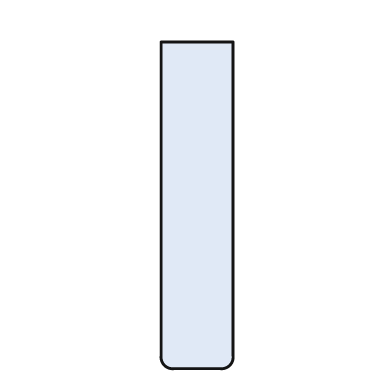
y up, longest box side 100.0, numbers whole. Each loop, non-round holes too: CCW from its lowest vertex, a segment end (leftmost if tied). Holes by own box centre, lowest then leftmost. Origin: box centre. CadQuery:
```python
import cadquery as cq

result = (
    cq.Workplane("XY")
    .moveTo(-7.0, -50.0)
    .lineTo(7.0, -50.0)
    .threePointArc((10.0, -49.0), (11.0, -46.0))
    .lineTo(11.0, 50.0)
    .lineTo(-11.0, 50.0)
    .lineTo(-11.0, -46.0)
    .threePointArc((-10.0, -49.0), (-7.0, -50.0))
    .close()
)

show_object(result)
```